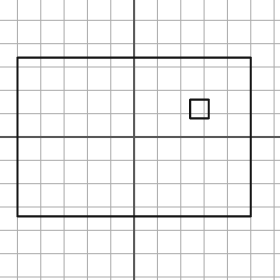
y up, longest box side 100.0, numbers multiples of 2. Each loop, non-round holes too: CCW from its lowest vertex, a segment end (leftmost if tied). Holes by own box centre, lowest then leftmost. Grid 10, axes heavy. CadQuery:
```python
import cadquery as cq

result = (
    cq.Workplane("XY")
    .moveTo(-50.0, -34.0)
    .lineTo(50.0, -34.0)
    .lineTo(50.0, 34.0)
    .lineTo(-50.0, 34.0)
    .close()
    .moveTo(24.0, 8.0)
    .lineTo(32.0, 8.0)
    .lineTo(32.0, 16.0)
    .lineTo(24.0, 16.0)
    .close()
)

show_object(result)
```